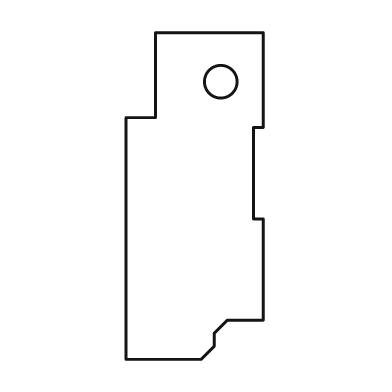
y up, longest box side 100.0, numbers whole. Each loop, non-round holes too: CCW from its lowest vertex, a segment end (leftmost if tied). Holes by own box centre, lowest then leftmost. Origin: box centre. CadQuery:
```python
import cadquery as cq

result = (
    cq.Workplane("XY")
    .moveTo(-21.0, -50.0)
    .lineTo(2.0, -50.0)
    .lineTo(6.0, -46.0)
    .lineTo(6.0, -42.0)
    .lineTo(10.0, -38.0)
    .lineTo(21.0, -38.0)
    .lineTo(21.0, -7.0)
    .lineTo(18.0, -7.0)
    .lineTo(18.0, 21.0)
    .lineTo(21.0, 21.0)
    .lineTo(21.0, 50.0)
    .lineTo(-12.0, 50.0)
    .lineTo(-12.0, 24.0)
    .lineTo(-21.0, 24.0)
    .close()
    .moveTo(8.0, 35.0)
    .circle(5.0)
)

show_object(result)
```